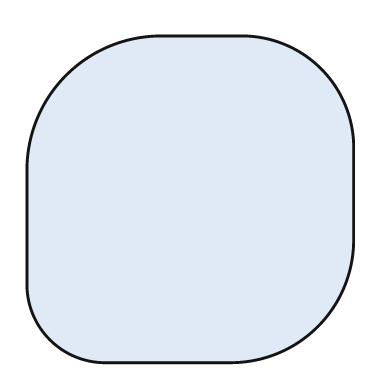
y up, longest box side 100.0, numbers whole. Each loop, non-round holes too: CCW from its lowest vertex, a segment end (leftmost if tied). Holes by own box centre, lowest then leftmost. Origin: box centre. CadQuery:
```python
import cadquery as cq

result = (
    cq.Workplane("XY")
    .moveTo(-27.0, -50.0)
    .lineTo(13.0, -50.0)
    .threePointArc((39.0, -39.0), (50.0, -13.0))
    .lineTo(50.0, 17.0)
    .threePointArc((40.0, 40.0), (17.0, 50.0))
    .lineTo(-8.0, 50.0)
    .threePointArc((-38.0, 38.0), (-50.0, 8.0))
    .lineTo(-50.0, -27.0)
    .threePointArc((-43.0, -43.0), (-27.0, -50.0))
    .close()
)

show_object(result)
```